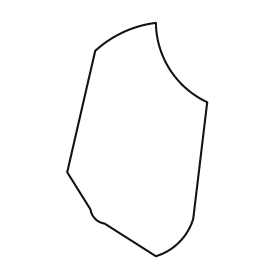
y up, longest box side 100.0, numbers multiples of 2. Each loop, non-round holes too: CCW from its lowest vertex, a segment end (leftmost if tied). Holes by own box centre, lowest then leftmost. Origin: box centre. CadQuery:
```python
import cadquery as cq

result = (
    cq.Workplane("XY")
    .moveTo(8.0, -50.0)
    .threePointArc((18.0, -44.0), (24.0, -34.0))
    .lineTo(30.0, 16.0)
    .threePointArc((14.0, 30.0), (8.0, 50.0))
    .threePointArc((-6.0, 46.0), (-18.0, 38.0))
    .lineTo(-30.0, -14.0)
    .lineTo(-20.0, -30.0)
    .threePointArc((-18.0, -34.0), (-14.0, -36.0))
    .close()
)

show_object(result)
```